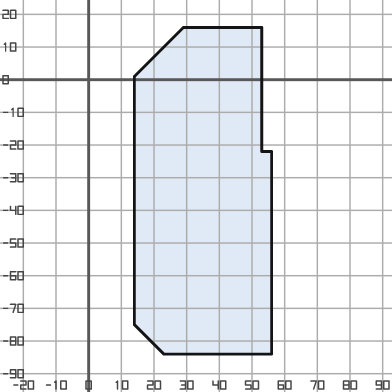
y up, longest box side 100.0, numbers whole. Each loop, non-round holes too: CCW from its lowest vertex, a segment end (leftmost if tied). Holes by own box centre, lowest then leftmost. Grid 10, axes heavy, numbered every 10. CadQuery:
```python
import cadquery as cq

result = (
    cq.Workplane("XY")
    .moveTo(23.0, -84.0)
    .lineTo(56.0, -84.0)
    .lineTo(56.0, -22.0)
    .lineTo(53.0, -22.0)
    .lineTo(53.0, 16.0)
    .lineTo(29.0, 16.0)
    .lineTo(14.0, 1.0)
    .lineTo(14.0, -75.0)
    .close()
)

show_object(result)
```